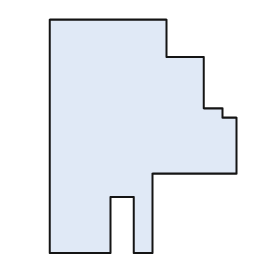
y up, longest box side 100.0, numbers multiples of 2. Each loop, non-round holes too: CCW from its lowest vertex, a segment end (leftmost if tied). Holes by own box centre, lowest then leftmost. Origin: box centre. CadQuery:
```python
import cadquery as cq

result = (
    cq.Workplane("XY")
    .moveTo(-40.0, -50.0)
    .lineTo(-14.0, -50.0)
    .lineTo(-14.0, -26.0)
    .lineTo(-4.0, -26.0)
    .lineTo(-4.0, -50.0)
    .lineTo(4.0, -50.0)
    .lineTo(4.0, -16.0)
    .lineTo(40.0, -16.0)
    .lineTo(40.0, 8.0)
    .lineTo(34.0, 8.0)
    .lineTo(34.0, 12.0)
    .lineTo(26.0, 12.0)
    .lineTo(26.0, 34.0)
    .lineTo(10.0, 34.0)
    .lineTo(10.0, 50.0)
    .lineTo(-40.0, 50.0)
    .close()
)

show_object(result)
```